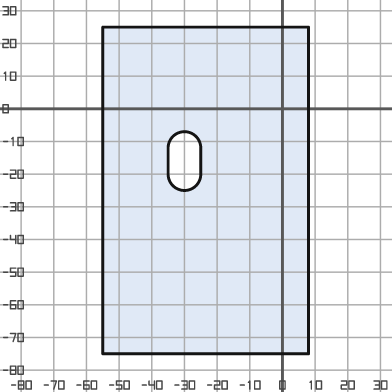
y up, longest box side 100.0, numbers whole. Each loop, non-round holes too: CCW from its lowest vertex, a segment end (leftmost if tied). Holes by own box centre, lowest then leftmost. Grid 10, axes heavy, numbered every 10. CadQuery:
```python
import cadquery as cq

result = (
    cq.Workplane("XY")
    .moveTo(-55.0, -75.0)
    .lineTo(8.0, -75.0)
    .lineTo(8.0, 25.0)
    .lineTo(-55.0, 25.0)
    .close()
    .moveTo(-35.0, -20.0)
    .threePointArc((-30.0, -25.0), (-25.0, -20.0))
    .lineTo(-25.0, -12.0)
    .threePointArc((-30.0, -7.0), (-35.0, -12.0))
    .close()
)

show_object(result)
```